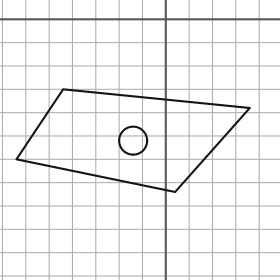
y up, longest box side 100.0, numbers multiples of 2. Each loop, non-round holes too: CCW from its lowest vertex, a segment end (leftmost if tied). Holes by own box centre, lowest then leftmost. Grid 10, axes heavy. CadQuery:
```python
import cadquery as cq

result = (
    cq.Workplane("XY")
    .moveTo(4.0, -74.0)
    .lineTo(36.0, -38.0)
    .lineTo(-44.0, -30.0)
    .lineTo(-64.0, -60.0)
    .close()
    .moveTo(-14.0, -52.0)
    .circle(6.0)
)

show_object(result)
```